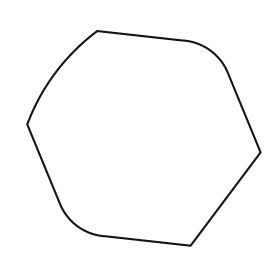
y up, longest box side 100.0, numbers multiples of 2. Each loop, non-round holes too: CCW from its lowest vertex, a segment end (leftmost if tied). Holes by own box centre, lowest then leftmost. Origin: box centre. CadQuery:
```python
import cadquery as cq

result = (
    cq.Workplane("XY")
    .moveTo(20.0, -46.0)
    .lineTo(50.0, -6.0)
    .lineTo(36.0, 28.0)
    .threePointArc((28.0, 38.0), (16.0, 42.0))
    .lineTo(-20.0, 46.0)
    .threePointArc((-38.0, 28.0), (-50.0, 6.0))
    .lineTo(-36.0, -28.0)
    .threePointArc((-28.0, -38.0), (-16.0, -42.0))
    .close()
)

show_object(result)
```